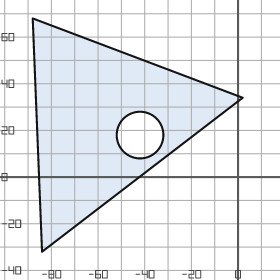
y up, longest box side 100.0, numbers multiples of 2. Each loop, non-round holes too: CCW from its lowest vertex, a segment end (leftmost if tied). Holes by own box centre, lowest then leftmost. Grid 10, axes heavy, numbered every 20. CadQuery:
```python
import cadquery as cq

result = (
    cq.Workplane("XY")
    .moveTo(-84.0, -32.0)
    .lineTo(2.0, 34.0)
    .lineTo(-88.0, 68.0)
    .close()
    .moveTo(-42.0, 18.0)
    .circle(10.0)
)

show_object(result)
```